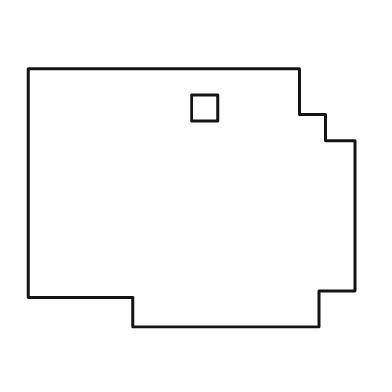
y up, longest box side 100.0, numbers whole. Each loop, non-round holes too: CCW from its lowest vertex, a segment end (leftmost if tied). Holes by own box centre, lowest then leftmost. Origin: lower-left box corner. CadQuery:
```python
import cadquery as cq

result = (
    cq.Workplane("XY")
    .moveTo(32.0, 0.0)
    .lineTo(89.0, 0.0)
    .lineTo(89.0, 11.0)
    .lineTo(100.0, 11.0)
    .lineTo(100.0, 57.0)
    .lineTo(91.0, 57.0)
    .lineTo(91.0, 65.0)
    .lineTo(83.0, 65.0)
    .lineTo(83.0, 79.0)
    .lineTo(0.0, 79.0)
    .lineTo(0.0, 9.0)
    .lineTo(32.0, 9.0)
    .close()
    .moveTo(50.0, 63.0)
    .lineTo(58.0, 63.0)
    .lineTo(58.0, 71.0)
    .lineTo(50.0, 71.0)
    .close()
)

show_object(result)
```